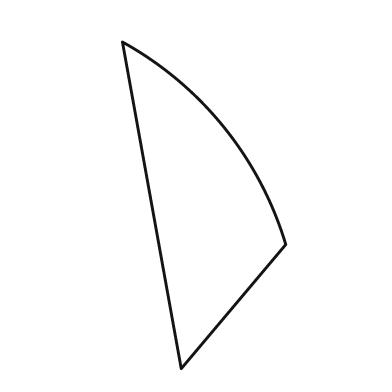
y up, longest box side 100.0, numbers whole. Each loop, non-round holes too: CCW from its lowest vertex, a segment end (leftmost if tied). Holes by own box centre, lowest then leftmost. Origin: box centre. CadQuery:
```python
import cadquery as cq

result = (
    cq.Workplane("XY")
    .moveTo(-7.0, -50.0)
    .lineTo(25.0, -12.0)
    .threePointArc((6.0, 24.0), (-25.0, 50.0))
    .close()
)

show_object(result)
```